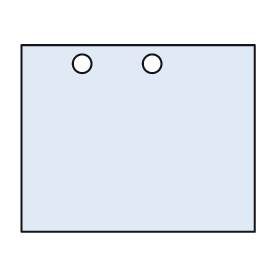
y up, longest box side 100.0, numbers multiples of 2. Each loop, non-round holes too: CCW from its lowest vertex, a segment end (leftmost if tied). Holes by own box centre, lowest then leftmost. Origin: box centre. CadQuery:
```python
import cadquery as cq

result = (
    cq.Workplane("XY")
    .moveTo(-50.0, -40.0)
    .lineTo(50.0, -40.0)
    .lineTo(50.0, 40.0)
    .lineTo(-50.0, 40.0)
    .close()
    .moveTo(-24.0, 32.0)
    .circle(4.0)
    .moveTo(6.0, 32.0)
    .circle(4.0)
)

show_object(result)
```